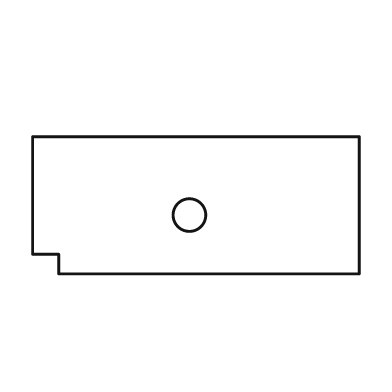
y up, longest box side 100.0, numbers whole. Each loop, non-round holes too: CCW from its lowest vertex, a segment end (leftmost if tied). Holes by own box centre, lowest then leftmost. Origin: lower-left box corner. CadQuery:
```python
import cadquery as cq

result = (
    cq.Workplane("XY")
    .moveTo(8.0, 0.0)
    .lineTo(100.0, 0.0)
    .lineTo(100.0, 42.0)
    .lineTo(0.0, 42.0)
    .lineTo(0.0, 6.0)
    .lineTo(8.0, 6.0)
    .close()
    .moveTo(48.0, 18.0)
    .circle(5.0)
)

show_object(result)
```